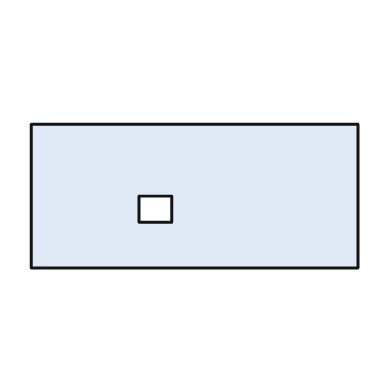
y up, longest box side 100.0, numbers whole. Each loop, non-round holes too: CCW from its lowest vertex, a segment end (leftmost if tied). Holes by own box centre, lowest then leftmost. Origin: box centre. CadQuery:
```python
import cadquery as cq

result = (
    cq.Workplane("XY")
    .moveTo(-50.0, -22.0)
    .lineTo(50.0, -22.0)
    .lineTo(50.0, 22.0)
    .lineTo(-50.0, 22.0)
    .close()
    .moveTo(-17.0, -8.0)
    .lineTo(-7.0, -8.0)
    .lineTo(-7.0, 0.0)
    .lineTo(-17.0, 0.0)
    .close()
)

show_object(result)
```